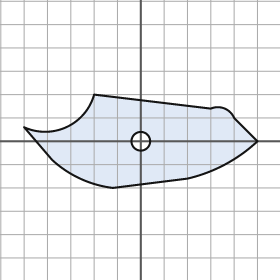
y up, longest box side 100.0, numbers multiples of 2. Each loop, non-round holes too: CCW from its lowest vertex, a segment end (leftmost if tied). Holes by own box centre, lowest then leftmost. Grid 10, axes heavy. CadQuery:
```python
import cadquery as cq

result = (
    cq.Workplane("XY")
    .moveTo(-12.0, -20.0)
    .lineTo(20.0, -16.0)
    .threePointArc((36.0, -10.0), (50.0, 0.0))
    .lineTo(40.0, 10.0)
    .threePointArc((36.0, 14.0), (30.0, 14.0))
    .lineTo(-20.0, 20.0)
    .threePointArc((-32.0, 6.0), (-50.0, 6.0))
    .lineTo(-38.0, -8.0)
    .threePointArc((-26.0, -16.0), (-12.0, -20.0))
    .close()
    .moveTo(0.0, 0.0)
    .circle(4.0)
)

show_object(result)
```